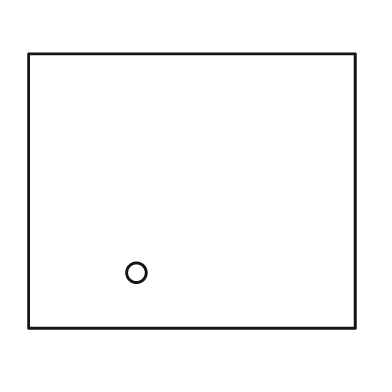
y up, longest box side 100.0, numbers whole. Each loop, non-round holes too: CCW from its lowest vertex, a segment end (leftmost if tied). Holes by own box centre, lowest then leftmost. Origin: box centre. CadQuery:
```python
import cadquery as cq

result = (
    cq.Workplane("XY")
    .moveTo(-50.0, -42.0)
    .lineTo(50.0, -42.0)
    .lineTo(50.0, 42.0)
    .lineTo(-50.0, 42.0)
    .close()
    .moveTo(-17.0, -25.0)
    .circle(3.0)
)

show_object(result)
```